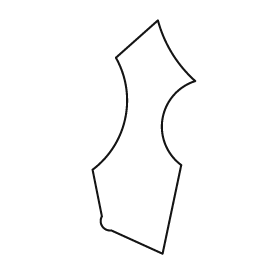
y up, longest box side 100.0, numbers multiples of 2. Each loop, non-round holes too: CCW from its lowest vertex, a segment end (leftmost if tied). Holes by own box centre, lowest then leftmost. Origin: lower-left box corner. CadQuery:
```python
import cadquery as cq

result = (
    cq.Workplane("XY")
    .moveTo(30.0, 0.0)
    .lineTo(38.0, 38.0)
    .threePointArc((30.0, 58.0), (44.0, 74.0))
    .threePointArc((34.0, 86.0), (28.0, 100.0))
    .lineTo(10.0, 84.0)
    .threePointArc((14.0, 58.0), (0.0, 36.0))
    .lineTo(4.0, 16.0)
    .threePointArc((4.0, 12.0), (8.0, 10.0))
    .close()
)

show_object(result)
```